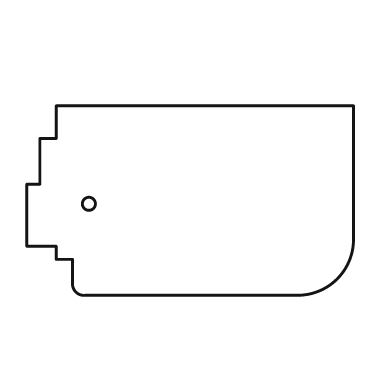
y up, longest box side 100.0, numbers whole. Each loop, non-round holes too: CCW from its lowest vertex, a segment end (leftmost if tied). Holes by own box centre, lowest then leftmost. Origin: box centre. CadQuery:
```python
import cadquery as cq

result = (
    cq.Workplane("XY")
    .moveTo(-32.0, -29.0)
    .lineTo(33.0, -29.0)
    .threePointArc((45.0, -24.0), (50.0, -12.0))
    .lineTo(50.0, 29.0)
    .lineTo(-41.0, 29.0)
    .lineTo(-41.0, 19.0)
    .lineTo(-46.0, 19.0)
    .lineTo(-46.0, 5.0)
    .lineTo(-50.0, 5.0)
    .lineTo(-50.0, -14.0)
    .lineTo(-41.0, -14.0)
    .lineTo(-41.0, -18.0)
    .lineTo(-36.0, -18.0)
    .lineTo(-36.0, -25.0)
    .threePointArc((-35.0, -28.0), (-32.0, -29.0))
    .close()
    .moveTo(-31.0, -1.0)
    .circle(2.0)
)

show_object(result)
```